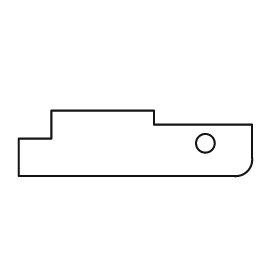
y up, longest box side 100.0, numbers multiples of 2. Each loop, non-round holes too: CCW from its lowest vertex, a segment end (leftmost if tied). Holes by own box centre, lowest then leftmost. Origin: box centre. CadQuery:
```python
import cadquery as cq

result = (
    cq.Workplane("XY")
    .moveTo(-50.0, -14.0)
    .lineTo(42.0, -14.0)
    .threePointArc((48.0, -12.0), (50.0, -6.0))
    .lineTo(50.0, 8.0)
    .lineTo(8.0, 8.0)
    .lineTo(8.0, 14.0)
    .lineTo(-36.0, 14.0)
    .lineTo(-36.0, 2.0)
    .lineTo(-50.0, 2.0)
    .close()
    .moveTo(30.0, 0.0)
    .circle(4.0)
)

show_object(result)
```